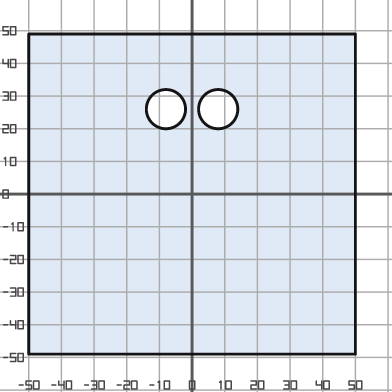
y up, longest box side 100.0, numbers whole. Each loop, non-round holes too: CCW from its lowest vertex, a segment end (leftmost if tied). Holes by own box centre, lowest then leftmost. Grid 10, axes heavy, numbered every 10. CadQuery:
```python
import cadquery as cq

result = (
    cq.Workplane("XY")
    .moveTo(-50.0, -49.0)
    .lineTo(50.0, -49.0)
    .lineTo(50.0, 49.0)
    .lineTo(-50.0, 49.0)
    .close()
    .moveTo(-8.0, 26.0)
    .circle(6.0)
    .moveTo(8.0, 26.0)
    .circle(6.0)
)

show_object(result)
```